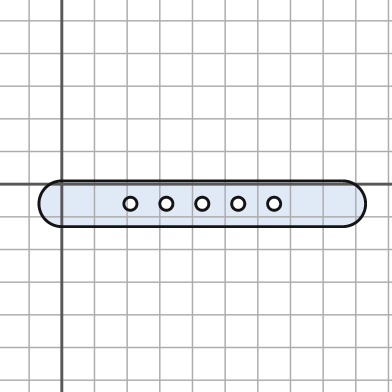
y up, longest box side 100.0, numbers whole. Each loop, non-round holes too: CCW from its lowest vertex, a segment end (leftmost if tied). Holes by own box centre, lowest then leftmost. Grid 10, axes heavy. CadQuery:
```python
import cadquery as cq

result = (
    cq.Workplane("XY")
    .moveTo(0.0, -13.0)
    .lineTo(86.0, -13.0)
    .threePointArc((93.0, -6.0), (86.0, 1.0))
    .lineTo(0.0, 1.0)
    .threePointArc((-7.0, -6.0), (0.0, -13.0))
    .close()
    .moveTo(21.0, -6.0)
    .circle(2.0)
    .moveTo(32.0, -6.0)
    .circle(2.0)
    .moveTo(43.0, -6.0)
    .circle(2.0)
    .moveTo(54.0, -6.0)
    .circle(2.0)
    .moveTo(65.0, -6.0)
    .circle(2.0)
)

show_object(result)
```